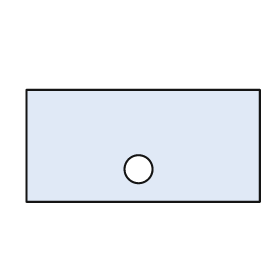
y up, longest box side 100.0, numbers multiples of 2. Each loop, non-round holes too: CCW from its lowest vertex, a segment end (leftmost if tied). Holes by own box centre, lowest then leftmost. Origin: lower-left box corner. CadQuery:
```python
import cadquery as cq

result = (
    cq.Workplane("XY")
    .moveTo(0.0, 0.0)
    .lineTo(100.0, 0.0)
    .lineTo(100.0, 48.0)
    .lineTo(0.0, 48.0)
    .close()
    .moveTo(48.0, 14.0)
    .circle(6.0)
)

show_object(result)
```